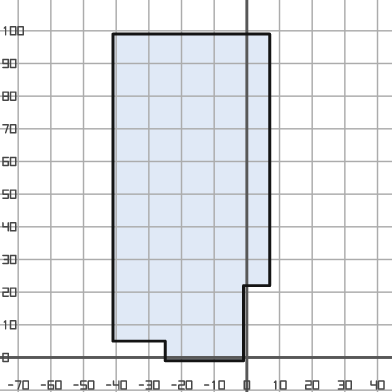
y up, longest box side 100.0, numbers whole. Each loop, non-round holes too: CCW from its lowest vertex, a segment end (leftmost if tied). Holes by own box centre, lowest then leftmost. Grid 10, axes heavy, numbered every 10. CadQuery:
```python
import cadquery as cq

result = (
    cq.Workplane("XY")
    .moveTo(-25.0, -1.0)
    .lineTo(-1.0, -1.0)
    .lineTo(-1.0, 22.0)
    .lineTo(7.0, 22.0)
    .lineTo(7.0, 99.0)
    .lineTo(-41.0, 99.0)
    .lineTo(-41.0, 5.0)
    .lineTo(-25.0, 5.0)
    .close()
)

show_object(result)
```